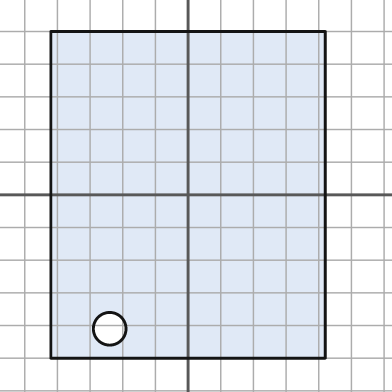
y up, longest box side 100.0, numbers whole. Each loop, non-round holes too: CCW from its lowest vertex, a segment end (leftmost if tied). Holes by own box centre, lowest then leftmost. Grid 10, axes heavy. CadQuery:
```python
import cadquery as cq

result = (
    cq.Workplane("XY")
    .moveTo(-42.0, -50.0)
    .lineTo(42.0, -50.0)
    .lineTo(42.0, 50.0)
    .lineTo(-42.0, 50.0)
    .close()
    .moveTo(-24.0, -41.0)
    .circle(5.0)
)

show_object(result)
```